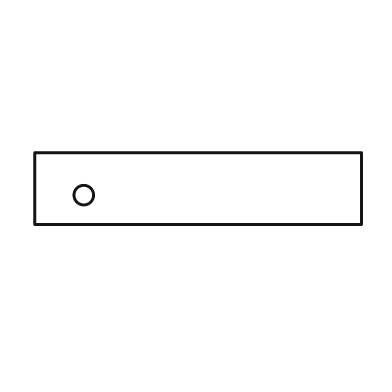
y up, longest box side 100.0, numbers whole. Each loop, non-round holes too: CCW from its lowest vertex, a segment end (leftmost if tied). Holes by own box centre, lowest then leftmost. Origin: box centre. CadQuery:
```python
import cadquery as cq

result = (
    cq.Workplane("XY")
    .moveTo(-50.0, -11.0)
    .lineTo(50.0, -11.0)
    .lineTo(50.0, 11.0)
    .lineTo(-50.0, 11.0)
    .close()
    .moveTo(-35.0, -2.0)
    .circle(3.0)
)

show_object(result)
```